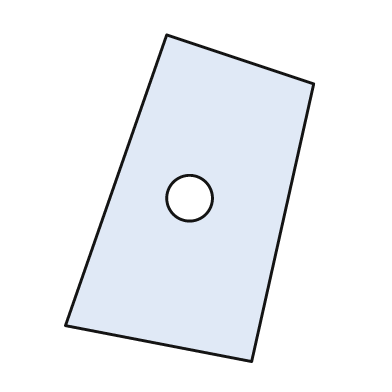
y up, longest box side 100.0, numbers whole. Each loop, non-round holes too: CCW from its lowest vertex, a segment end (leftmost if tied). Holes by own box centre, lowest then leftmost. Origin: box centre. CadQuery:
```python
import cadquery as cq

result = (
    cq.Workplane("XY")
    .moveTo(19.0, -50.0)
    .lineTo(38.0, 35.0)
    .lineTo(-7.0, 50.0)
    .lineTo(-38.0, -39.0)
    .close()
    .moveTo(0.0, 0.0)
    .circle(7.0)
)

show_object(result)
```